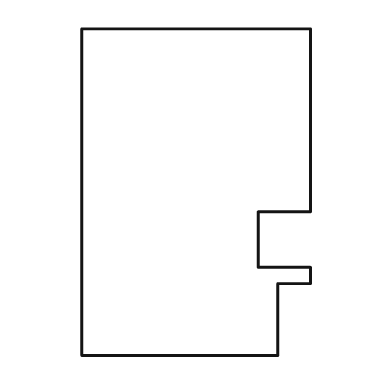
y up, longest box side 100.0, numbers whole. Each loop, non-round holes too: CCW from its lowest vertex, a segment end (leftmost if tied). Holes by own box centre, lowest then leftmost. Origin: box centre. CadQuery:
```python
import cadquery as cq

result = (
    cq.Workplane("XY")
    .moveTo(-35.0, -50.0)
    .lineTo(25.0, -50.0)
    .lineTo(25.0, -28.0)
    .lineTo(35.0, -28.0)
    .lineTo(35.0, -23.0)
    .lineTo(19.0, -23.0)
    .lineTo(19.0, -6.0)
    .lineTo(35.0, -6.0)
    .lineTo(35.0, 50.0)
    .lineTo(-35.0, 50.0)
    .close()
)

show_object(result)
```